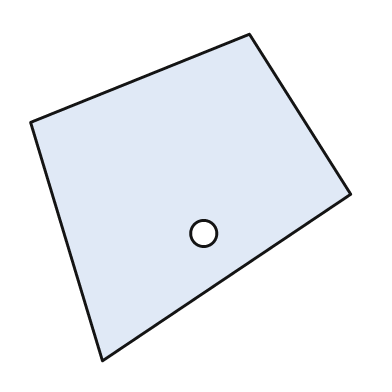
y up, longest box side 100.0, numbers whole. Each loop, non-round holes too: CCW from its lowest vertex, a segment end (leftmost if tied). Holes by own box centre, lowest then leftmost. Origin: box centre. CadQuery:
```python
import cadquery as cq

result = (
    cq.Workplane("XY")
    .moveTo(-27.0, -50.0)
    .lineTo(49.0, 1.0)
    .lineTo(18.0, 50.0)
    .lineTo(-49.0, 23.0)
    .close()
    .moveTo(4.0, -11.0)
    .circle(4.0)
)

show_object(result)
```